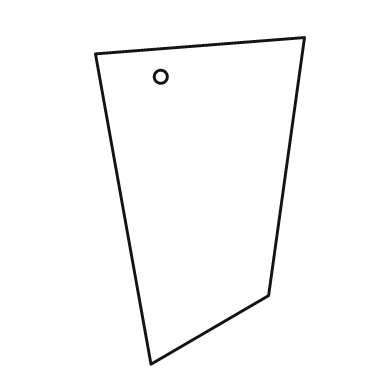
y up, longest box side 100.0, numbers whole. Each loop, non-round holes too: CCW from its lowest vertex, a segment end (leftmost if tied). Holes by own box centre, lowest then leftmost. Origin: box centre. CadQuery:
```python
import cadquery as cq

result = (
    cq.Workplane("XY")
    .moveTo(-15.0, -50.0)
    .lineTo(21.0, -29.0)
    .lineTo(32.0, 50.0)
    .lineTo(-32.0, 45.0)
    .close()
    .moveTo(-12.0, 38.0)
    .circle(2.0)
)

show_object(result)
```